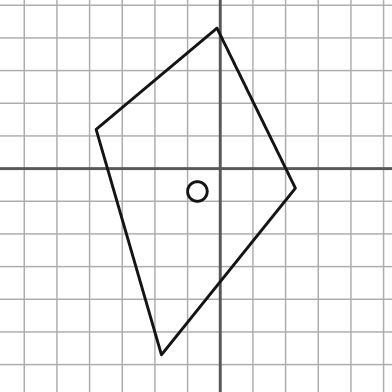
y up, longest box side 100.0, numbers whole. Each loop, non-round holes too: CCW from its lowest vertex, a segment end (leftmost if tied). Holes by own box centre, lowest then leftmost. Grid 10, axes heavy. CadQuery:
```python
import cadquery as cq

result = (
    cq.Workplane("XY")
    .moveTo(-18.0, -57.0)
    .lineTo(23.0, -6.0)
    .lineTo(-1.0, 43.0)
    .lineTo(-38.0, 12.0)
    .close()
    .moveTo(-7.0, -7.0)
    .circle(3.0)
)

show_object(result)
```